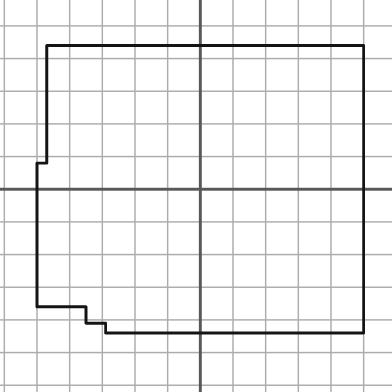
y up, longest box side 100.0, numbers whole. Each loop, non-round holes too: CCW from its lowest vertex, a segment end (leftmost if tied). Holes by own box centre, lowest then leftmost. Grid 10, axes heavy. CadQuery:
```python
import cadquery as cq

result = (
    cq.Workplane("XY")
    .moveTo(-29.0, -44.0)
    .lineTo(50.0, -44.0)
    .lineTo(50.0, 44.0)
    .lineTo(-47.0, 44.0)
    .lineTo(-47.0, 8.0)
    .lineTo(-50.0, 8.0)
    .lineTo(-50.0, -36.0)
    .lineTo(-35.0, -36.0)
    .lineTo(-35.0, -41.0)
    .lineTo(-29.0, -41.0)
    .close()
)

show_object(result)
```